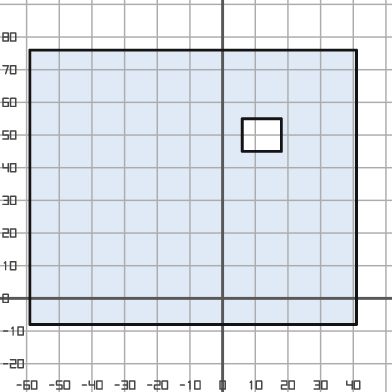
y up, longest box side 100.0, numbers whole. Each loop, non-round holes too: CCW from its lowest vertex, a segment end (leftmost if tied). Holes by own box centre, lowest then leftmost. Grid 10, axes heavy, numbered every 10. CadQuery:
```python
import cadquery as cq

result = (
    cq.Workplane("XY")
    .moveTo(-59.0, -8.0)
    .lineTo(41.0, -8.0)
    .lineTo(41.0, 76.0)
    .lineTo(-59.0, 76.0)
    .close()
    .moveTo(6.0, 45.0)
    .lineTo(18.0, 45.0)
    .lineTo(18.0, 55.0)
    .lineTo(6.0, 55.0)
    .close()
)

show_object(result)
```